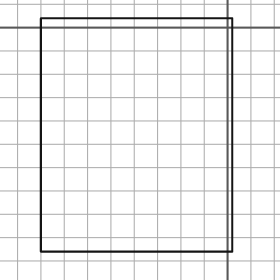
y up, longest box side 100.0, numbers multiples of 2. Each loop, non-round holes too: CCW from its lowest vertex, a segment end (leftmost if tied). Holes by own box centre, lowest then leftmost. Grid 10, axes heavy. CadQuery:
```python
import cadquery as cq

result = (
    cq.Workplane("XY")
    .moveTo(-80.0, -96.0)
    .lineTo(2.0, -96.0)
    .lineTo(2.0, 4.0)
    .lineTo(-80.0, 4.0)
    .close()
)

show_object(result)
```